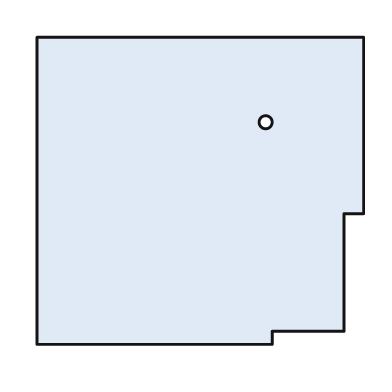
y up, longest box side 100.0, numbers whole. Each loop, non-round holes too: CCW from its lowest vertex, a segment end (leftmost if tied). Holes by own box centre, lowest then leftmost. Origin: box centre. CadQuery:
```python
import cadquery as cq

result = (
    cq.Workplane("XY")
    .moveTo(-50.0, -47.0)
    .lineTo(22.0, -47.0)
    .lineTo(22.0, -43.0)
    .lineTo(44.0, -43.0)
    .lineTo(44.0, -7.0)
    .lineTo(50.0, -7.0)
    .lineTo(50.0, 47.0)
    .lineTo(-50.0, 47.0)
    .close()
    .moveTo(20.0, 21.0)
    .circle(2.0)
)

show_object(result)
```